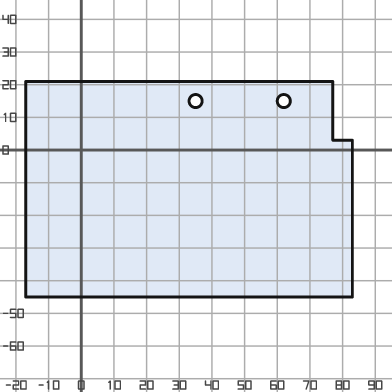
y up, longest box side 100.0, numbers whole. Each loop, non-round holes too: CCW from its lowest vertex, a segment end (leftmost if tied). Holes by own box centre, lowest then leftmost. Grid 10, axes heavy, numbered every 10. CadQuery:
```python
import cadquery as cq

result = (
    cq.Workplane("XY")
    .moveTo(-17.0, -45.0)
    .lineTo(83.0, -45.0)
    .lineTo(83.0, 3.0)
    .lineTo(77.0, 3.0)
    .lineTo(77.0, 21.0)
    .lineTo(-17.0, 21.0)
    .close()
    .moveTo(35.0, 15.0)
    .circle(2.0)
    .moveTo(62.0, 15.0)
    .circle(2.0)
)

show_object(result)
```